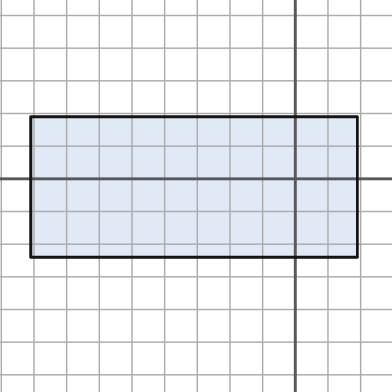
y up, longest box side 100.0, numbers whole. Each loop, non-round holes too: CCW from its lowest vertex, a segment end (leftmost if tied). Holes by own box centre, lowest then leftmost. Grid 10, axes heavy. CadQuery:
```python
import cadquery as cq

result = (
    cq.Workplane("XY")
    .moveTo(-81.0, -24.0)
    .lineTo(19.0, -24.0)
    .lineTo(19.0, 19.0)
    .lineTo(-81.0, 19.0)
    .close()
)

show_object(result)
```